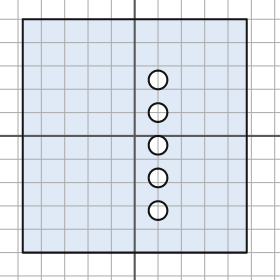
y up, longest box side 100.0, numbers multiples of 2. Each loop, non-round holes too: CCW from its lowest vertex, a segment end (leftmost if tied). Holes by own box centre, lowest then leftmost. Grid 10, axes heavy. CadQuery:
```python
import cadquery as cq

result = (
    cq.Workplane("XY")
    .moveTo(-48.0, -50.0)
    .lineTo(48.0, -50.0)
    .lineTo(48.0, 50.0)
    .lineTo(-48.0, 50.0)
    .close()
    .moveTo(10.0, -32.0)
    .circle(4.0)
    .moveTo(10.0, -18.0)
    .circle(4.0)
    .moveTo(10.0, -4.0)
    .circle(4.0)
    .moveTo(10.0, 10.0)
    .circle(4.0)
    .moveTo(10.0, 24.0)
    .circle(4.0)
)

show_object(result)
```